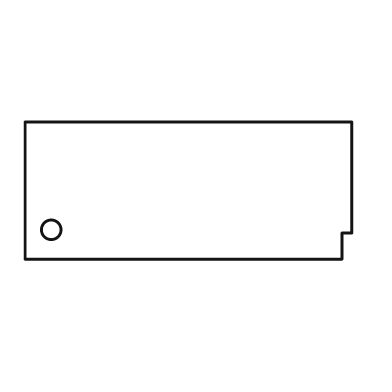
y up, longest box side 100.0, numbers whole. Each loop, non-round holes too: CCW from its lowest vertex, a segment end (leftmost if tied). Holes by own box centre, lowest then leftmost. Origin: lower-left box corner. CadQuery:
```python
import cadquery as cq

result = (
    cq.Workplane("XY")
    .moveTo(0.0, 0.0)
    .lineTo(97.0, 0.0)
    .lineTo(97.0, 8.0)
    .lineTo(100.0, 8.0)
    .lineTo(100.0, 42.0)
    .lineTo(0.0, 42.0)
    .close()
    .moveTo(8.0, 9.0)
    .circle(3.0)
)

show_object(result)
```